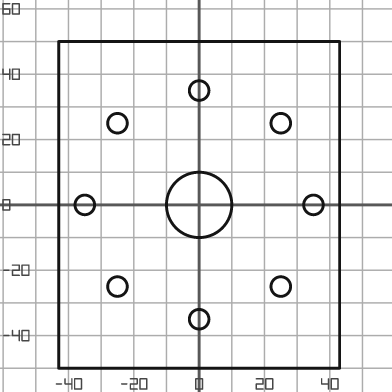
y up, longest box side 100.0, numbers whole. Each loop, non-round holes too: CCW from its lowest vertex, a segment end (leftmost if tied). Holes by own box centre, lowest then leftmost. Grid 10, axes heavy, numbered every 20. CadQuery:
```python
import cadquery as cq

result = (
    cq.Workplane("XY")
    .moveTo(-43.0, -50.0)
    .lineTo(43.0, -50.0)
    .lineTo(43.0, 50.0)
    .lineTo(-43.0, 50.0)
    .close()
    .moveTo(0.0, -35.0)
    .circle(3.0)
    .moveTo(-25.0, -25.0)
    .circle(3.0)
    .moveTo(25.0, -25.0)
    .circle(3.0)
    .moveTo(-35.0, 0.0)
    .circle(3.0)
    .moveTo(0.0, 0.0)
    .circle(10.0)
    .moveTo(35.0, 0.0)
    .circle(3.0)
    .moveTo(-25.0, 25.0)
    .circle(3.0)
    .moveTo(25.0, 25.0)
    .circle(3.0)
    .moveTo(0.0, 35.0)
    .circle(3.0)
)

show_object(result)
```